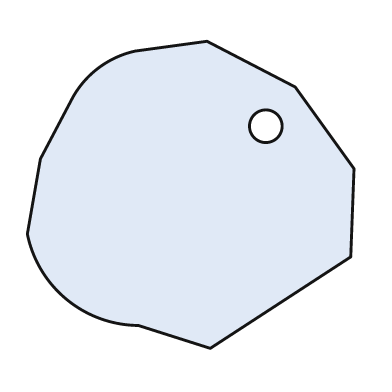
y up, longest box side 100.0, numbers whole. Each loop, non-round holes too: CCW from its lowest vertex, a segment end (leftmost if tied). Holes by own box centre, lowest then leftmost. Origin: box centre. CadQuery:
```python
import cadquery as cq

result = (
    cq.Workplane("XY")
    .moveTo(6.0, -47.0)
    .lineTo(49.0, -19.0)
    .lineTo(50.0, 8.0)
    .lineTo(32.0, 33.0)
    .lineTo(5.0, 47.0)
    .lineTo(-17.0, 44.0)
    .threePointArc((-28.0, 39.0), (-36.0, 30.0))
    .lineTo(-46.0, 11.0)
    .lineTo(-50.0, -12.0)
    .threePointArc((-38.0, -32.0), (-16.0, -40.0))
    .close()
    .moveTo(23.0, 21.0)
    .circle(5.0)
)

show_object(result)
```